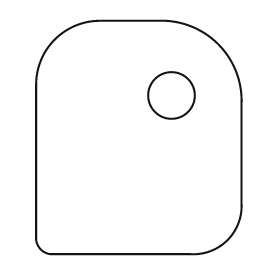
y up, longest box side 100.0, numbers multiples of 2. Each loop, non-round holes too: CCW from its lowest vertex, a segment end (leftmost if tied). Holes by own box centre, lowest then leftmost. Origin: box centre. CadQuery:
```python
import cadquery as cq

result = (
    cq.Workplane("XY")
    .moveTo(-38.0, -50.0)
    .lineTo(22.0, -50.0)
    .threePointArc((38.0, -44.0), (44.0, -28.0))
    .lineTo(44.0, 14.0)
    .threePointArc((34.0, 40.0), (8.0, 50.0))
    .lineTo(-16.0, 50.0)
    .threePointArc((-36.0, 42.0), (-44.0, 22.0))
    .lineTo(-44.0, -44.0)
    .threePointArc((-42.0, -48.0), (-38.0, -50.0))
    .close()
    .moveTo(14.0, 18.0)
    .circle(10.0)
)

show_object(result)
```